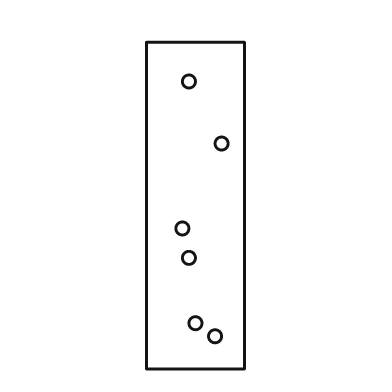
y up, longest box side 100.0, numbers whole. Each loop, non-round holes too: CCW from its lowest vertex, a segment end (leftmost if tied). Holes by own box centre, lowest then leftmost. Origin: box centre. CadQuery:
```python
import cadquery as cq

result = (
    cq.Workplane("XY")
    .moveTo(-15.0, -50.0)
    .lineTo(15.0, -50.0)
    .lineTo(15.0, 50.0)
    .lineTo(-15.0, 50.0)
    .close()
    .moveTo(6.0, -40.0)
    .circle(2.0)
    .moveTo(0.0, -36.0)
    .circle(2.0)
    .moveTo(-2.0, -16.0)
    .circle(2.0)
    .moveTo(-4.0, -7.0)
    .circle(2.0)
    .moveTo(8.0, 19.0)
    .circle(2.0)
    .moveTo(-2.0, 38.0)
    .circle(2.0)
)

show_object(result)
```